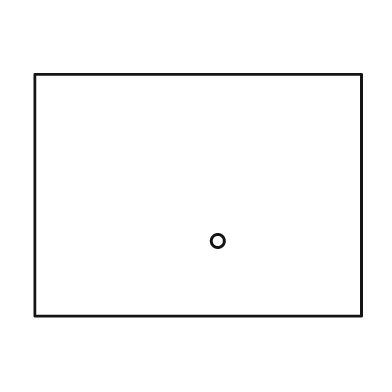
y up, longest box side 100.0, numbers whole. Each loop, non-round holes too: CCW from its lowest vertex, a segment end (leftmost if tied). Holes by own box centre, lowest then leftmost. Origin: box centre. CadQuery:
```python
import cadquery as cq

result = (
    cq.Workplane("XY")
    .moveTo(-50.0, -37.0)
    .lineTo(50.0, -37.0)
    .lineTo(50.0, 37.0)
    .lineTo(-50.0, 37.0)
    .close()
    .moveTo(6.0, -14.0)
    .circle(2.0)
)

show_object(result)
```